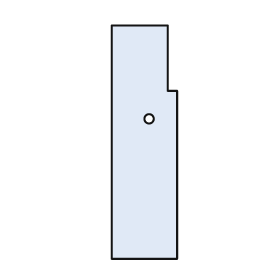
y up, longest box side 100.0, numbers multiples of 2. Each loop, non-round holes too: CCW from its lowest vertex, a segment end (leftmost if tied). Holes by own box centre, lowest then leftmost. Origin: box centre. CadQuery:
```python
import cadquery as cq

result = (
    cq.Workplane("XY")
    .moveTo(-14.0, -50.0)
    .lineTo(14.0, -50.0)
    .lineTo(14.0, 22.0)
    .lineTo(10.0, 22.0)
    .lineTo(10.0, 50.0)
    .lineTo(-14.0, 50.0)
    .close()
    .moveTo(2.0, 10.0)
    .circle(2.0)
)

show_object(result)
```